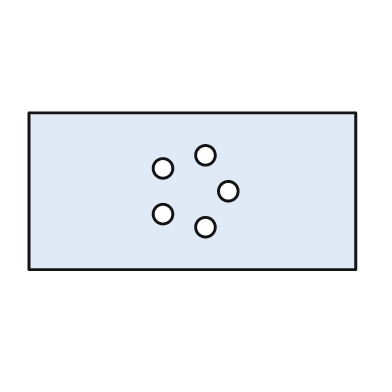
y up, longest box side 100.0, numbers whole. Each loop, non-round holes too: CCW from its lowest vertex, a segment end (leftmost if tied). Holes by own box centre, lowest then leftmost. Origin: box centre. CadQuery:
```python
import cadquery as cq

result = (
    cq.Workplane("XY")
    .moveTo(-50.0, -24.0)
    .lineTo(50.0, -24.0)
    .lineTo(50.0, 24.0)
    .lineTo(-50.0, 24.0)
    .close()
    .moveTo(4.0, -11.0)
    .circle(3.0)
    .moveTo(-9.0, -7.0)
    .circle(3.0)
    .moveTo(11.0, 0.0)
    .circle(3.0)
    .moveTo(-9.0, 7.0)
    .circle(3.0)
    .moveTo(4.0, 11.0)
    .circle(3.0)
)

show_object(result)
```